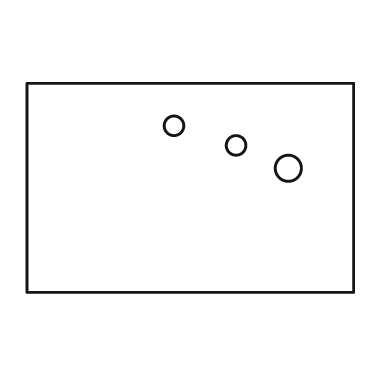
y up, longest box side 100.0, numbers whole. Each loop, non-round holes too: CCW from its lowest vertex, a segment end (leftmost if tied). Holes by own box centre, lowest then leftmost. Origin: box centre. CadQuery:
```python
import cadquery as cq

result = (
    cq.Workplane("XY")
    .moveTo(-50.0, -32.0)
    .lineTo(50.0, -32.0)
    .lineTo(50.0, 32.0)
    .lineTo(-50.0, 32.0)
    .close()
    .moveTo(30.0, 6.0)
    .circle(4.0)
    .moveTo(14.0, 13.0)
    .circle(3.0)
    .moveTo(-5.0, 19.0)
    .circle(3.0)
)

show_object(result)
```